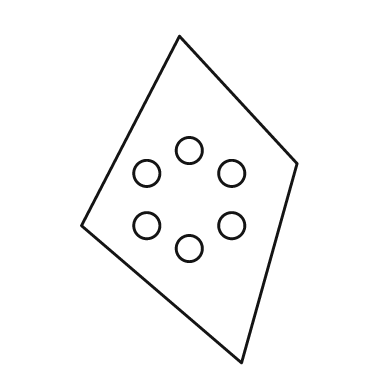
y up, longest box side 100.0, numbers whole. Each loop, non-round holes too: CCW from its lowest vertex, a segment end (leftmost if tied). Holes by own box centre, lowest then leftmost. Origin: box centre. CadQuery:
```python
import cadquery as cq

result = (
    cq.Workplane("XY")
    .moveTo(16.0, -50.0)
    .lineTo(33.0, 11.0)
    .lineTo(-3.0, 50.0)
    .lineTo(-33.0, -8.0)
    .close()
    .moveTo(0.0, -15.0)
    .circle(4.0)
    .moveTo(-13.0, -8.0)
    .circle(4.0)
    .moveTo(13.0, -8.0)
    .circle(4.0)
    .moveTo(-13.0, 8.0)
    .circle(4.0)
    .moveTo(13.0, 8.0)
    .circle(4.0)
    .moveTo(0.0, 15.0)
    .circle(4.0)
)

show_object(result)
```